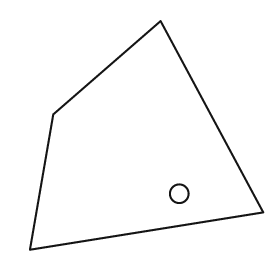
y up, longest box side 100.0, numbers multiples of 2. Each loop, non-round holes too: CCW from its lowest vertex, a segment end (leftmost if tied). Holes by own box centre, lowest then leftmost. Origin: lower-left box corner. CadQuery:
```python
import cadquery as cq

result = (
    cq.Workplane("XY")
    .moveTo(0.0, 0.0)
    .lineTo(100.0, 16.0)
    .lineTo(56.0, 98.0)
    .lineTo(10.0, 58.0)
    .close()
    .moveTo(64.0, 24.0)
    .circle(4.0)
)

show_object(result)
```